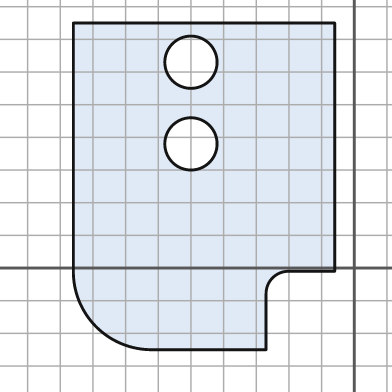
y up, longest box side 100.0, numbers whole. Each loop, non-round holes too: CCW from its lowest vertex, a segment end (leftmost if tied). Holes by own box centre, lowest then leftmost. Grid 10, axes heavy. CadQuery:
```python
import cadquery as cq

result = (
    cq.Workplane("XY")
    .moveTo(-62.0, -25.0)
    .lineTo(-27.0, -25.0)
    .lineTo(-27.0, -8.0)
    .threePointArc((-25.0, -3.0), (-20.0, -1.0))
    .lineTo(-6.0, -1.0)
    .lineTo(-6.0, 75.0)
    .lineTo(-86.0, 75.0)
    .lineTo(-86.0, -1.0)
    .threePointArc((-79.0, -18.0), (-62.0, -25.0))
    .close()
    .moveTo(-50.0, 38.0)
    .circle(8.0)
    .moveTo(-50.0, 63.0)
    .circle(8.0)
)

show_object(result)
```